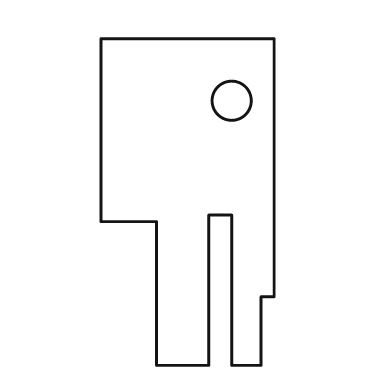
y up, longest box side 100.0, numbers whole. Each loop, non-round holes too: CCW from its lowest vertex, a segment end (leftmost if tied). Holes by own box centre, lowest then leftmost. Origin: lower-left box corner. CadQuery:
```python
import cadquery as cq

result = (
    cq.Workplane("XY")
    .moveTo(17.0, 0.0)
    .lineTo(33.0, 0.0)
    .lineTo(33.0, 46.0)
    .lineTo(40.0, 46.0)
    .lineTo(40.0, 0.0)
    .lineTo(49.0, 0.0)
    .lineTo(49.0, 21.0)
    .lineTo(53.0, 21.0)
    .lineTo(53.0, 100.0)
    .lineTo(0.0, 100.0)
    .lineTo(0.0, 44.0)
    .lineTo(17.0, 44.0)
    .close()
    .moveTo(40.0, 81.0)
    .circle(6.0)
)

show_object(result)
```